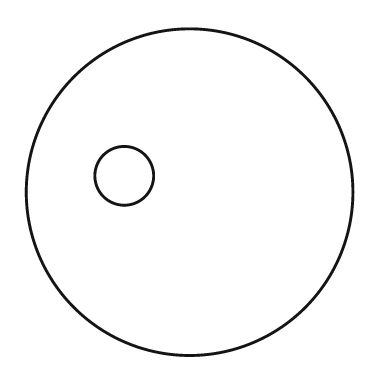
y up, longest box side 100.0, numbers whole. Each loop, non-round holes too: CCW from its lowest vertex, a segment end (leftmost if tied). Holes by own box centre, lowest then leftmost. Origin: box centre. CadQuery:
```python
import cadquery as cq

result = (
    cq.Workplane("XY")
    .moveTo(0.0, 0.0)
    .circle(50.0)
    .moveTo(-20.0, 5.0)
    .circle(9.0)
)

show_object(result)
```